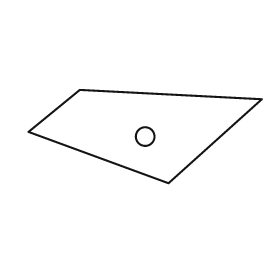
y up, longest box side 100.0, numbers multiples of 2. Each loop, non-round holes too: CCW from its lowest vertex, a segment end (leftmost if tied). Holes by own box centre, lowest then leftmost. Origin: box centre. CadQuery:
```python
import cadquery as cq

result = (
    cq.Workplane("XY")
    .moveTo(10.0, -20.0)
    .lineTo(50.0, 16.0)
    .lineTo(-28.0, 20.0)
    .lineTo(-50.0, 2.0)
    .close()
    .moveTo(0.0, 0.0)
    .circle(4.0)
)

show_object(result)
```